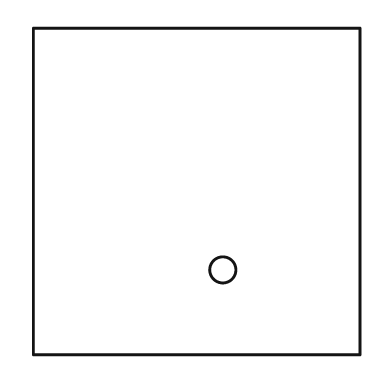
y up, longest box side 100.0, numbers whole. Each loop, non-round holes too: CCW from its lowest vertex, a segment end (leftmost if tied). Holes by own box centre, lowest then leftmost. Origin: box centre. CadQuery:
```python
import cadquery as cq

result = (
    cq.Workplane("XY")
    .moveTo(-50.0, -50.0)
    .lineTo(50.0, -50.0)
    .lineTo(50.0, 50.0)
    .lineTo(-50.0, 50.0)
    .close()
    .moveTo(8.0, -24.0)
    .circle(4.0)
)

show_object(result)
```